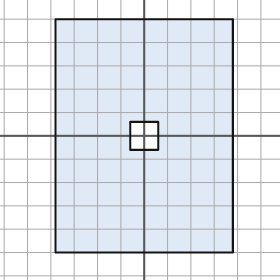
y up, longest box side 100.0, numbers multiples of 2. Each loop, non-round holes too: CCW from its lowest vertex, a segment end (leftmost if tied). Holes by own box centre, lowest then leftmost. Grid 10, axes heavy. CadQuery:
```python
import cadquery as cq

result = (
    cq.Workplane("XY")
    .moveTo(-38.0, -50.0)
    .lineTo(38.0, -50.0)
    .lineTo(38.0, 50.0)
    .lineTo(-38.0, 50.0)
    .close()
    .moveTo(-6.0, -6.0)
    .lineTo(6.0, -6.0)
    .lineTo(6.0, 6.0)
    .lineTo(-6.0, 6.0)
    .close()
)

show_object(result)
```